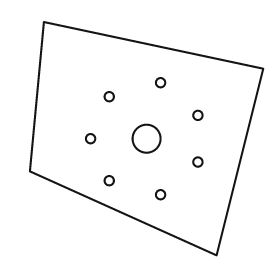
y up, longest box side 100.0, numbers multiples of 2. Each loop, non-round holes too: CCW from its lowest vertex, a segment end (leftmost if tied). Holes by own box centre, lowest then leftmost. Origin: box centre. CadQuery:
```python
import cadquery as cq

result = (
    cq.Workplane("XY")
    .moveTo(30.0, -50.0)
    .lineTo(50.0, 30.0)
    .lineTo(-44.0, 50.0)
    .lineTo(-50.0, -14.0)
    .close()
    .moveTo(6.0, -24.0)
    .circle(2.0)
    .moveTo(-16.0, -18.0)
    .circle(2.0)
    .moveTo(22.0, -10.0)
    .circle(2.0)
    .moveTo(-24.0, 0.0)
    .circle(2.0)
    .moveTo(0.0, 0.0)
    .circle(6.0)
    .moveTo(22.0, 10.0)
    .circle(2.0)
    .moveTo(-16.0, 18.0)
    .circle(2.0)
    .moveTo(6.0, 24.0)
    .circle(2.0)
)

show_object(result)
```